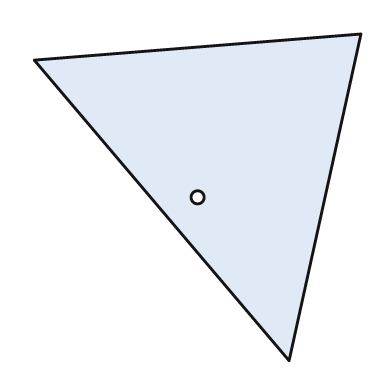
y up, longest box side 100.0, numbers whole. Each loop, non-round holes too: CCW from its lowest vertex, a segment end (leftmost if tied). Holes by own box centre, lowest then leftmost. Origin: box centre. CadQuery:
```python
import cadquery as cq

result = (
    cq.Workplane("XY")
    .moveTo(28.0, -50.0)
    .lineTo(50.0, 50.0)
    .lineTo(-50.0, 42.0)
    .close()
    .moveTo(0.0, 0.0)
    .circle(2.0)
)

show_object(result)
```